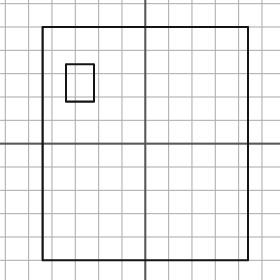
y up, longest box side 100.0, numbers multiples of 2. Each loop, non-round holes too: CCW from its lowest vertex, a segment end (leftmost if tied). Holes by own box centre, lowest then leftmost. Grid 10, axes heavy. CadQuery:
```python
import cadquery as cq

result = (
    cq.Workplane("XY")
    .moveTo(-44.0, -50.0)
    .lineTo(44.0, -50.0)
    .lineTo(44.0, 50.0)
    .lineTo(-44.0, 50.0)
    .close()
    .moveTo(-34.0, 18.0)
    .lineTo(-22.0, 18.0)
    .lineTo(-22.0, 34.0)
    .lineTo(-34.0, 34.0)
    .close()
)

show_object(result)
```